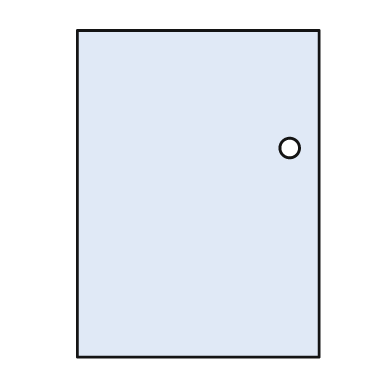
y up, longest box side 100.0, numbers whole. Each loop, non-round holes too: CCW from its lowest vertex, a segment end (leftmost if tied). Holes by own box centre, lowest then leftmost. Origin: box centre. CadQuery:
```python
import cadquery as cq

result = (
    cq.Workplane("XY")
    .moveTo(-37.0, -50.0)
    .lineTo(37.0, -50.0)
    .lineTo(37.0, 50.0)
    .lineTo(-37.0, 50.0)
    .close()
    .moveTo(28.0, 14.0)
    .circle(3.0)
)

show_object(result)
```